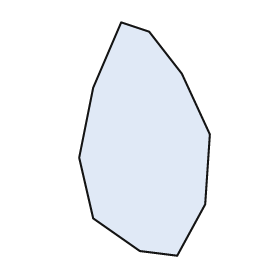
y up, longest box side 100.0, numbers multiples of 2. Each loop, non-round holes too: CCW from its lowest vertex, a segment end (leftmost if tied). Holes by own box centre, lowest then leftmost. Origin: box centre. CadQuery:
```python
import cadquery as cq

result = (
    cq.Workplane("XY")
    .moveTo(14.0, -50.0)
    .lineTo(26.0, -28.0)
    .lineTo(28.0, 2.0)
    .lineTo(16.0, 28.0)
    .lineTo(2.0, 46.0)
    .lineTo(-10.0, 50.0)
    .lineTo(-22.0, 22.0)
    .lineTo(-28.0, -8.0)
    .lineTo(-22.0, -34.0)
    .lineTo(-2.0, -48.0)
    .close()
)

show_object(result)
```